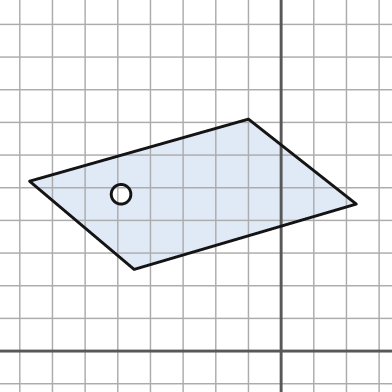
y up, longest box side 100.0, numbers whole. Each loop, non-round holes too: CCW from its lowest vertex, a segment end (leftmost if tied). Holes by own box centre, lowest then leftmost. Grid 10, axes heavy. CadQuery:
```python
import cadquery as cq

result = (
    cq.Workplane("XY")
    .moveTo(-45.0, 25.0)
    .lineTo(23.0, 45.0)
    .lineTo(-10.0, 71.0)
    .lineTo(-77.0, 52.0)
    .close()
    .moveTo(-49.0, 48.0)
    .circle(3.0)
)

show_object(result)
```